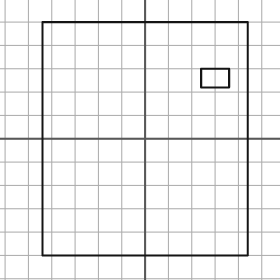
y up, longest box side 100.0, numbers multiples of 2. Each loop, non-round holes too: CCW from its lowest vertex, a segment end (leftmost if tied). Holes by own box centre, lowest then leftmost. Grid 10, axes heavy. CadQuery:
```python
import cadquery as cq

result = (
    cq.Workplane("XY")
    .moveTo(-44.0, -50.0)
    .lineTo(44.0, -50.0)
    .lineTo(44.0, 50.0)
    .lineTo(-44.0, 50.0)
    .close()
    .moveTo(24.0, 22.0)
    .lineTo(36.0, 22.0)
    .lineTo(36.0, 30.0)
    .lineTo(24.0, 30.0)
    .close()
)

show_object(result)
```